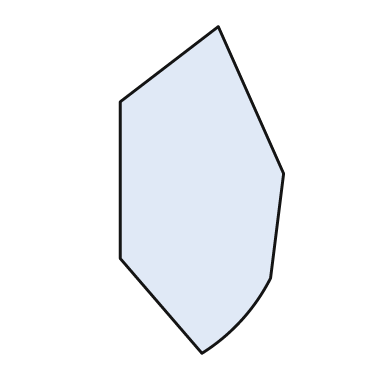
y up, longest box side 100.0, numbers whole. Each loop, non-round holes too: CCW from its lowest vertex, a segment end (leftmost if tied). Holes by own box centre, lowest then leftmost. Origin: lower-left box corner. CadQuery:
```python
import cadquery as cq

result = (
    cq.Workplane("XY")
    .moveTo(25.0, 0.0)
    .threePointArc((37.0, 10.0), (46.0, 23.0))
    .lineTo(50.0, 55.0)
    .lineTo(30.0, 100.0)
    .lineTo(0.0, 77.0)
    .lineTo(0.0, 29.0)
    .close()
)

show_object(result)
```